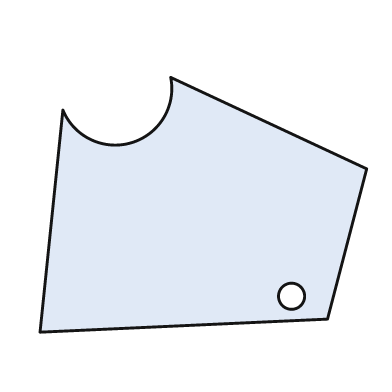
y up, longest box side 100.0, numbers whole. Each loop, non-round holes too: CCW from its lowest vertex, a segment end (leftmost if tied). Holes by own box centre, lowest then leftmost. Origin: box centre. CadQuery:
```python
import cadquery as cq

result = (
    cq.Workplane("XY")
    .moveTo(-50.0, -39.0)
    .lineTo(38.0, -35.0)
    .lineTo(50.0, 11.0)
    .lineTo(-10.0, 39.0)
    .threePointArc((-22.0, 19.0), (-43.0, 29.0))
    .close()
    .moveTo(27.0, -28.0)
    .circle(4.0)
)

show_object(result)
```